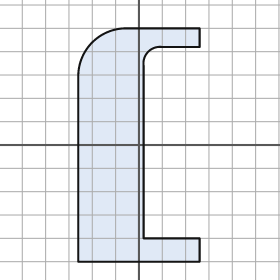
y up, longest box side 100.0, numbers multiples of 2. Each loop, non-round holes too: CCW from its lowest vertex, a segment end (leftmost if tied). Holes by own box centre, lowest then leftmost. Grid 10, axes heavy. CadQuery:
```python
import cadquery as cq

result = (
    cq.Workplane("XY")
    .moveTo(-26.0, -50.0)
    .lineTo(26.0, -50.0)
    .lineTo(26.0, -40.0)
    .lineTo(2.0, -40.0)
    .lineTo(2.0, 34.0)
    .threePointArc((4.0, 40.0), (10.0, 42.0))
    .lineTo(26.0, 42.0)
    .lineTo(26.0, 50.0)
    .lineTo(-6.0, 50.0)
    .threePointArc((-20.0, 44.0), (-26.0, 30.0))
    .close()
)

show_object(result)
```